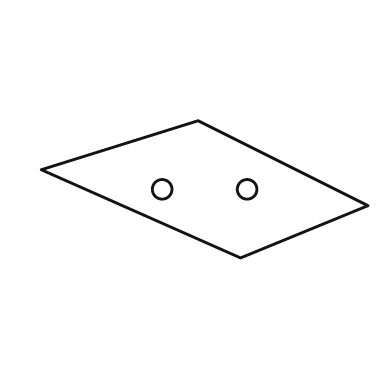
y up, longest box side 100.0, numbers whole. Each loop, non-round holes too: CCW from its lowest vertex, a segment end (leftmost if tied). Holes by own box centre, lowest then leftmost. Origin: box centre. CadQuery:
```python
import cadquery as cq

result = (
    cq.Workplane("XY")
    .moveTo(11.0, -21.0)
    .lineTo(50.0, -5.0)
    .lineTo(-2.0, 21.0)
    .lineTo(-50.0, 6.0)
    .close()
    .moveTo(-13.0, 0.0)
    .circle(3.0)
    .moveTo(13.0, 0.0)
    .circle(3.0)
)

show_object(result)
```